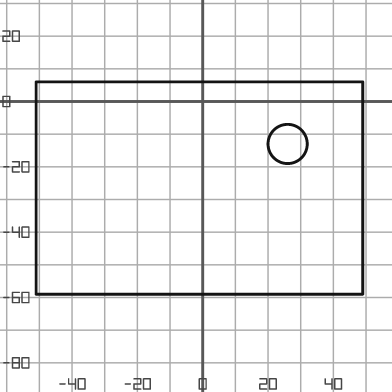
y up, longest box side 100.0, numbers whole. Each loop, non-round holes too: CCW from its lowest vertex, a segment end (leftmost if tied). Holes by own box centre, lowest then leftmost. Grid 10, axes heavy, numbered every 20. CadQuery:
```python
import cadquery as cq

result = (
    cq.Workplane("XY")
    .moveTo(-51.0, -59.0)
    .lineTo(49.0, -59.0)
    .lineTo(49.0, 6.0)
    .lineTo(-51.0, 6.0)
    .close()
    .moveTo(26.0, -13.0)
    .circle(6.0)
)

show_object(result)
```